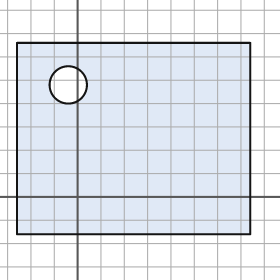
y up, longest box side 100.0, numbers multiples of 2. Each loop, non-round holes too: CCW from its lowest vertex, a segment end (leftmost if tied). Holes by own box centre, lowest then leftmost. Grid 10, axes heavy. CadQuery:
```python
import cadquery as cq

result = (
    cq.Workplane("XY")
    .moveTo(-26.0, -16.0)
    .lineTo(74.0, -16.0)
    .lineTo(74.0, 66.0)
    .lineTo(-26.0, 66.0)
    .close()
    .moveTo(-4.0, 48.0)
    .circle(8.0)
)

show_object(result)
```